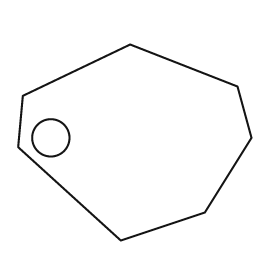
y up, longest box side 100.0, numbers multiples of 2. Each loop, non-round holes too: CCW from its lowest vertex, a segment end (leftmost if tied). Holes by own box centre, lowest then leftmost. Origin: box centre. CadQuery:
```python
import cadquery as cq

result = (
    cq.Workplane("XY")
    .moveTo(-6.0, -42.0)
    .lineTo(30.0, -30.0)
    .lineTo(50.0, 2.0)
    .lineTo(44.0, 24.0)
    .lineTo(-2.0, 42.0)
    .lineTo(-48.0, 20.0)
    .lineTo(-50.0, -2.0)
    .close()
    .moveTo(-36.0, 2.0)
    .circle(8.0)
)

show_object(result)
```